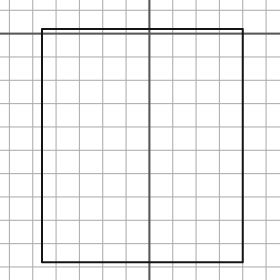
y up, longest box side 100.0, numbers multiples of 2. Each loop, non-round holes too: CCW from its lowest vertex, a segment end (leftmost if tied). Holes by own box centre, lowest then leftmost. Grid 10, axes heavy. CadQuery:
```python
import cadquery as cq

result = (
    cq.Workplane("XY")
    .moveTo(-46.0, -98.0)
    .lineTo(40.0, -98.0)
    .lineTo(40.0, 2.0)
    .lineTo(-46.0, 2.0)
    .close()
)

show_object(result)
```